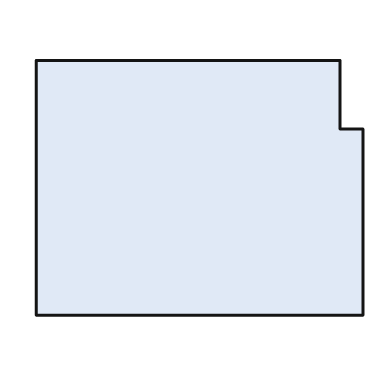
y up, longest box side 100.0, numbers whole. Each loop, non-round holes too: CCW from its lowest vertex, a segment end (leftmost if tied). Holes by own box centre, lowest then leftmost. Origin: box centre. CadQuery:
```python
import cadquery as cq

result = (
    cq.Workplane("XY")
    .moveTo(-50.0, -39.0)
    .lineTo(50.0, -39.0)
    .lineTo(50.0, 18.0)
    .lineTo(43.0, 18.0)
    .lineTo(43.0, 39.0)
    .lineTo(-50.0, 39.0)
    .close()
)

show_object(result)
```